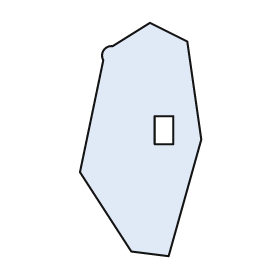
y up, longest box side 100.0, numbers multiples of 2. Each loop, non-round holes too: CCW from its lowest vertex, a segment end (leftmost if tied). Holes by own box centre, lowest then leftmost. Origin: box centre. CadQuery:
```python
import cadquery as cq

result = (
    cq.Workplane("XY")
    .moveTo(12.0, -50.0)
    .lineTo(26.0, 0.0)
    .lineTo(20.0, 42.0)
    .lineTo(4.0, 50.0)
    .lineTo(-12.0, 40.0)
    .threePointArc((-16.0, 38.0), (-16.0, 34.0))
    .lineTo(-26.0, -14.0)
    .lineTo(-4.0, -48.0)
    .close()
    .moveTo(6.0, -2.0)
    .lineTo(14.0, -2.0)
    .lineTo(14.0, 10.0)
    .lineTo(6.0, 10.0)
    .close()
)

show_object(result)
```